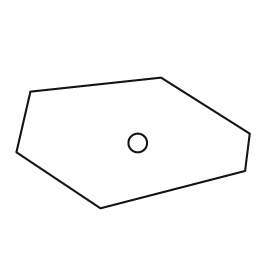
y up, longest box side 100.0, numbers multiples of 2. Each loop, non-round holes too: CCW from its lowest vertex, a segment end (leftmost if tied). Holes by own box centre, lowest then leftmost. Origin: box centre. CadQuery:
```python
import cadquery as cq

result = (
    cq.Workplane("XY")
    .moveTo(-14.0, -28.0)
    .lineTo(48.0, -12.0)
    .lineTo(50.0, 4.0)
    .lineTo(12.0, 28.0)
    .lineTo(-44.0, 22.0)
    .lineTo(-50.0, -4.0)
    .close()
    .moveTo(2.0, 0.0)
    .circle(4.0)
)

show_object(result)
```